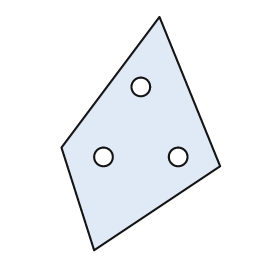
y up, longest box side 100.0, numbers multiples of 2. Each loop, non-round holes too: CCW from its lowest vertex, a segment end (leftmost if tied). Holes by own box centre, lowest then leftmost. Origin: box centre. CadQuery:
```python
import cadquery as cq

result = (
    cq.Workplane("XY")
    .moveTo(-20.0, -50.0)
    .lineTo(34.0, -14.0)
    .lineTo(8.0, 50.0)
    .lineTo(-34.0, -6.0)
    .close()
    .moveTo(-16.0, -10.0)
    .circle(4.0)
    .moveTo(16.0, -10.0)
    .circle(4.0)
    .moveTo(0.0, 20.0)
    .circle(4.0)
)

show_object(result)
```